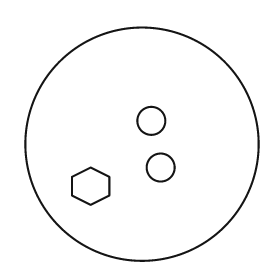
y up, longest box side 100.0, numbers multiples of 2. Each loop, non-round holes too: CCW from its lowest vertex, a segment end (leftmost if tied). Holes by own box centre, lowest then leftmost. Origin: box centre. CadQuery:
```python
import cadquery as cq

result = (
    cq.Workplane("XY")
    .moveTo(0.0, 0.0)
    .circle(50.0)
    .moveTo(-22.0, -26.0)
    .lineTo(-14.0, -22.0)
    .lineTo(-14.0, -14.0)
    .lineTo(-22.0, -10.0)
    .lineTo(-30.0, -14.0)
    .lineTo(-30.0, -22.0)
    .close()
    .moveTo(8.0, -10.0)
    .circle(6.0)
    .moveTo(4.0, 10.0)
    .circle(6.0)
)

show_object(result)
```